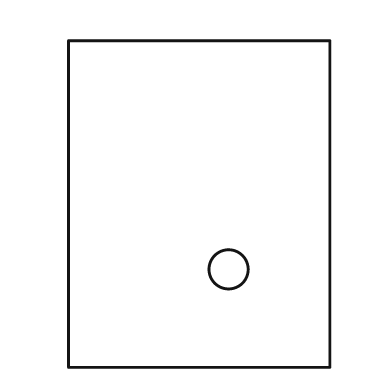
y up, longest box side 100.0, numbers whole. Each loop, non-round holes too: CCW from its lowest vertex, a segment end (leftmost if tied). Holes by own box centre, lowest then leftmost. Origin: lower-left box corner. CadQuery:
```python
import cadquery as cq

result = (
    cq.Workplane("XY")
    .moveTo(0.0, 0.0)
    .lineTo(80.0, 0.0)
    .lineTo(80.0, 100.0)
    .lineTo(0.0, 100.0)
    .close()
    .moveTo(49.0, 30.0)
    .circle(6.0)
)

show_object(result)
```